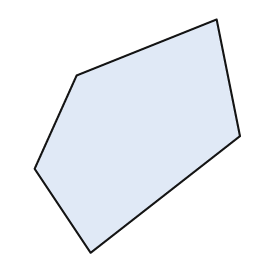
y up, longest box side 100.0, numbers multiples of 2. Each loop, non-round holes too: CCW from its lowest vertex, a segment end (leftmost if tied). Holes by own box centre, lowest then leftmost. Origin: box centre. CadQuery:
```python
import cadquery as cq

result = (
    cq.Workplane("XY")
    .moveTo(-20.0, -50.0)
    .lineTo(44.0, 0.0)
    .lineTo(34.0, 50.0)
    .lineTo(-26.0, 26.0)
    .lineTo(-44.0, -14.0)
    .close()
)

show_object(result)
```